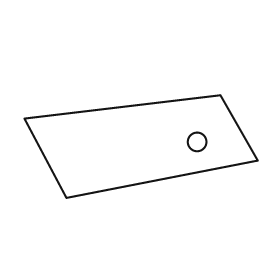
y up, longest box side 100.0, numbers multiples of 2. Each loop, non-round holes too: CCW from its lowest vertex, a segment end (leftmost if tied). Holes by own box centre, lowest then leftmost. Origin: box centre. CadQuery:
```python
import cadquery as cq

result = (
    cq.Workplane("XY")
    .moveTo(-32.0, -22.0)
    .lineTo(50.0, -6.0)
    .lineTo(34.0, 22.0)
    .lineTo(-50.0, 12.0)
    .close()
    .moveTo(24.0, 2.0)
    .circle(4.0)
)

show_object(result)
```